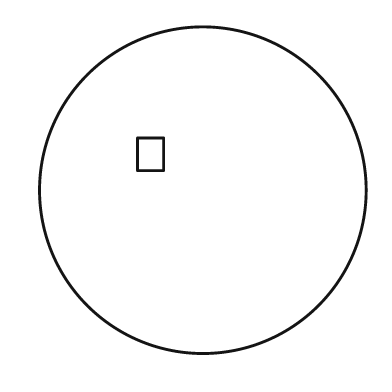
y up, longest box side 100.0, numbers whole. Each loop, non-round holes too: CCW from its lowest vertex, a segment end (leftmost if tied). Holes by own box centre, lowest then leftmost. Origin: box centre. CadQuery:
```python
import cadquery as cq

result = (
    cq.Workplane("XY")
    .moveTo(0.0, 0.0)
    .circle(50.0)
    .moveTo(-20.0, 6.0)
    .lineTo(-12.0, 6.0)
    .lineTo(-12.0, 16.0)
    .lineTo(-20.0, 16.0)
    .close()
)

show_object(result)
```